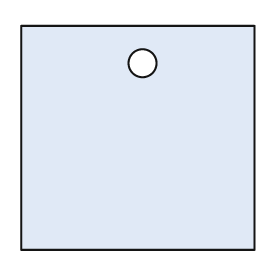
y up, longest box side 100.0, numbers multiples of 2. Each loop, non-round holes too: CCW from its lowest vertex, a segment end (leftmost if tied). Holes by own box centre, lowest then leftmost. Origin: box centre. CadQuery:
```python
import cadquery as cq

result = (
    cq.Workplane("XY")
    .moveTo(-50.0, -48.0)
    .lineTo(50.0, -48.0)
    .lineTo(50.0, 48.0)
    .lineTo(-50.0, 48.0)
    .close()
    .moveTo(2.0, 32.0)
    .circle(6.0)
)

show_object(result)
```